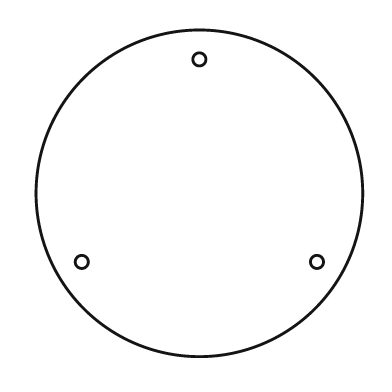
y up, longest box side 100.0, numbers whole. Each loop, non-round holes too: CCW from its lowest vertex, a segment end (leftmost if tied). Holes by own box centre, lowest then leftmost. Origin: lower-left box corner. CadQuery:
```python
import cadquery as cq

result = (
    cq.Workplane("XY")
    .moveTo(50.0, 50.0)
    .circle(50.0)
    .moveTo(14.0, 29.0)
    .circle(2.0)
    .moveTo(86.0, 29.0)
    .circle(2.0)
    .moveTo(50.0, 91.0)
    .circle(2.0)
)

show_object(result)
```